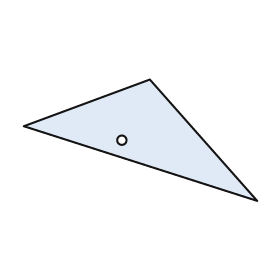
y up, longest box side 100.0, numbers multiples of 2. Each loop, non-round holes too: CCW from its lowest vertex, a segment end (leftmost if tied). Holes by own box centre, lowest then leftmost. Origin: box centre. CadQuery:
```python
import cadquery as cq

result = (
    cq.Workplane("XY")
    .moveTo(50.0, -26.0)
    .lineTo(4.0, 26.0)
    .lineTo(-50.0, 6.0)
    .close()
    .moveTo(-8.0, 0.0)
    .circle(2.0)
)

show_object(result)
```